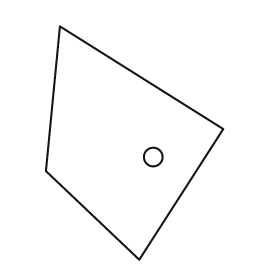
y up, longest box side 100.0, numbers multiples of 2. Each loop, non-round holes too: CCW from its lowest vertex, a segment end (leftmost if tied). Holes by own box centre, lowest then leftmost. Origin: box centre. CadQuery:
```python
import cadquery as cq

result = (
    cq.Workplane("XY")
    .moveTo(2.0, -50.0)
    .lineTo(38.0, 6.0)
    .lineTo(-32.0, 50.0)
    .lineTo(-38.0, -12.0)
    .close()
    .moveTo(8.0, -6.0)
    .circle(4.0)
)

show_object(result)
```